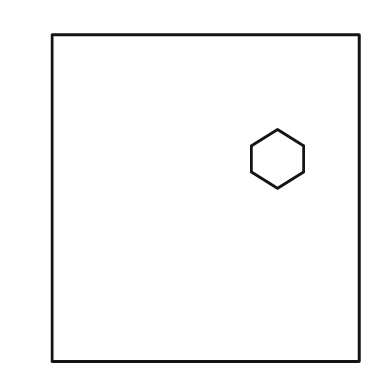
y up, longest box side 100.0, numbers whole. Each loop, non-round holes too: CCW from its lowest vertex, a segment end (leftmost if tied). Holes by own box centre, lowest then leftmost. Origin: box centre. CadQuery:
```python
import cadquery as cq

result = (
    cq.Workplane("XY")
    .moveTo(-47.0, -50.0)
    .lineTo(47.0, -50.0)
    .lineTo(47.0, 50.0)
    .lineTo(-47.0, 50.0)
    .close()
    .moveTo(22.0, 3.0)
    .lineTo(30.0, 8.0)
    .lineTo(30.0, 16.0)
    .lineTo(22.0, 21.0)
    .lineTo(14.0, 16.0)
    .lineTo(14.0, 8.0)
    .close()
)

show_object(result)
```